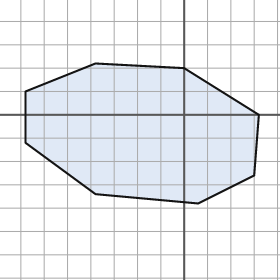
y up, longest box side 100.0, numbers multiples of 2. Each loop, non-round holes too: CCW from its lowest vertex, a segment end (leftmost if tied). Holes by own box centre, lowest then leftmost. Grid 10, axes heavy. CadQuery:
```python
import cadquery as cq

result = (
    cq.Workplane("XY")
    .moveTo(6.0, -38.0)
    .lineTo(30.0, -26.0)
    .lineTo(32.0, 0.0)
    .lineTo(0.0, 20.0)
    .lineTo(-38.0, 22.0)
    .lineTo(-68.0, 10.0)
    .lineTo(-68.0, -12.0)
    .lineTo(-38.0, -34.0)
    .close()
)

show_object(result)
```